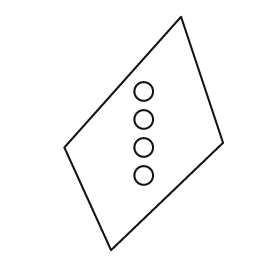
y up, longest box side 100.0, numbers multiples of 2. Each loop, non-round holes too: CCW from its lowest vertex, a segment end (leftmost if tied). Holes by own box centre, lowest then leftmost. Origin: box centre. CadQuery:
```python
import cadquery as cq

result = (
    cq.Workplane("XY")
    .moveTo(-14.0, -50.0)
    .lineTo(34.0, -4.0)
    .lineTo(16.0, 50.0)
    .lineTo(-34.0, -6.0)
    .close()
    .moveTo(0.0, -18.0)
    .circle(4.0)
    .moveTo(0.0, -6.0)
    .circle(4.0)
    .moveTo(0.0, 6.0)
    .circle(4.0)
    .moveTo(0.0, 18.0)
    .circle(4.0)
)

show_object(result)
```